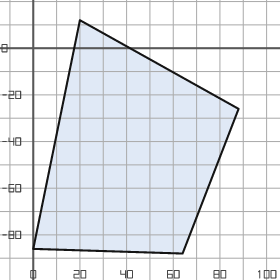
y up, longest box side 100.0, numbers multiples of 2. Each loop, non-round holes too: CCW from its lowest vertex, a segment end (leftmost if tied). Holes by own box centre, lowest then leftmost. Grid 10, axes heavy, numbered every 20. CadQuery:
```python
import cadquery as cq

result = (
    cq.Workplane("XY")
    .moveTo(64.0, -88.0)
    .lineTo(88.0, -26.0)
    .lineTo(20.0, 12.0)
    .lineTo(0.0, -86.0)
    .close()
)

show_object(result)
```